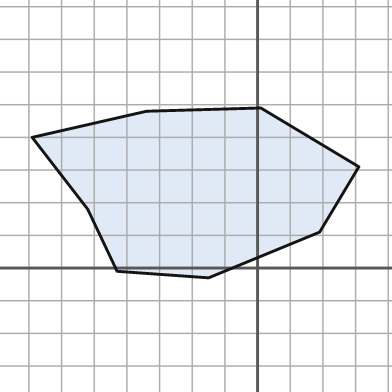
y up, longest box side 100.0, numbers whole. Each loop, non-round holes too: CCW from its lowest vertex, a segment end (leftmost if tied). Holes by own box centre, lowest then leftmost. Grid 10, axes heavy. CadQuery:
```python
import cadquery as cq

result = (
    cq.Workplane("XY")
    .moveTo(-15.0, -3.0)
    .lineTo(19.0, 11.0)
    .lineTo(31.0, 31.0)
    .lineTo(1.0, 49.0)
    .lineTo(-34.0, 48.0)
    .lineTo(-69.0, 40.0)
    .lineTo(-52.0, 18.0)
    .lineTo(-43.0, -1.0)
    .close()
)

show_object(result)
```